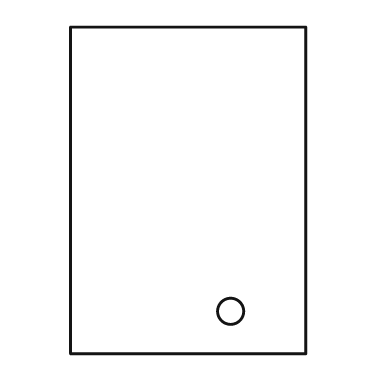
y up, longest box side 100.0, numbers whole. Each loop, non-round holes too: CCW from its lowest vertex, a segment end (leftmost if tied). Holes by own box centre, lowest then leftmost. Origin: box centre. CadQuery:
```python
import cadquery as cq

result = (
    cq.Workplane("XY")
    .moveTo(-36.0, -50.0)
    .lineTo(36.0, -50.0)
    .lineTo(36.0, 50.0)
    .lineTo(-36.0, 50.0)
    .close()
    .moveTo(13.0, -37.0)
    .circle(4.0)
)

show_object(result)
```